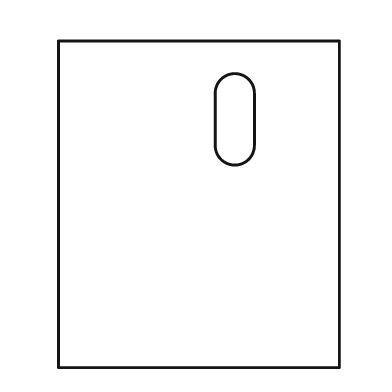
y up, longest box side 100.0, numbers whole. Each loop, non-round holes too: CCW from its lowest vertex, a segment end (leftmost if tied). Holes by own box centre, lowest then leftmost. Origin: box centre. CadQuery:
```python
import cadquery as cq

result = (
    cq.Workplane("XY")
    .moveTo(-43.0, -50.0)
    .lineTo(43.0, -50.0)
    .lineTo(43.0, 50.0)
    .lineTo(-43.0, 50.0)
    .close()
    .moveTo(5.0, 18.0)
    .threePointArc((11.0, 12.0), (17.0, 18.0))
    .lineTo(17.0, 34.0)
    .threePointArc((11.0, 40.0), (5.0, 34.0))
    .close()
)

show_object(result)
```